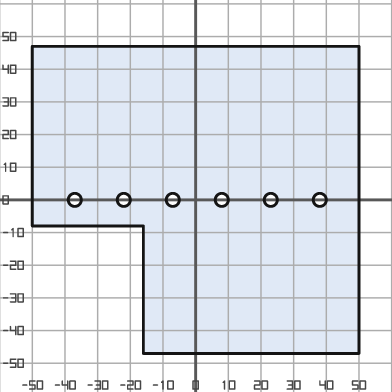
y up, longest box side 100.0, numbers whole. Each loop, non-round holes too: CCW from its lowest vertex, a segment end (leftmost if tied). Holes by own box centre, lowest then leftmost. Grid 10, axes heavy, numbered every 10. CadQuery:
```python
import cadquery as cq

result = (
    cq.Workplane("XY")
    .moveTo(-16.0, -47.0)
    .lineTo(50.0, -47.0)
    .lineTo(50.0, 47.0)
    .lineTo(-50.0, 47.0)
    .lineTo(-50.0, -8.0)
    .lineTo(-16.0, -8.0)
    .close()
    .moveTo(-37.0, 0.0)
    .circle(2.0)
    .moveTo(-22.0, 0.0)
    .circle(2.0)
    .moveTo(-7.0, 0.0)
    .circle(2.0)
    .moveTo(8.0, 0.0)
    .circle(2.0)
    .moveTo(23.0, 0.0)
    .circle(2.0)
    .moveTo(38.0, 0.0)
    .circle(2.0)
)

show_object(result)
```